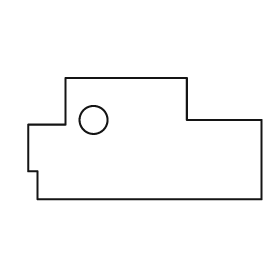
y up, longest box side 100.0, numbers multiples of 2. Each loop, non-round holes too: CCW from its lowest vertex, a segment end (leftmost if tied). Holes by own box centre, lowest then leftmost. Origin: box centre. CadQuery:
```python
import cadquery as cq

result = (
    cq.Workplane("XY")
    .moveTo(-46.0, -26.0)
    .lineTo(50.0, -26.0)
    .lineTo(50.0, 8.0)
    .lineTo(18.0, 8.0)
    .lineTo(18.0, 26.0)
    .lineTo(-34.0, 26.0)
    .lineTo(-34.0, 6.0)
    .lineTo(-50.0, 6.0)
    .lineTo(-50.0, -14.0)
    .lineTo(-46.0, -14.0)
    .close()
    .moveTo(-22.0, 8.0)
    .circle(6.0)
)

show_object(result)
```